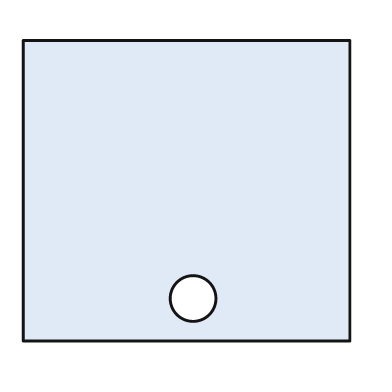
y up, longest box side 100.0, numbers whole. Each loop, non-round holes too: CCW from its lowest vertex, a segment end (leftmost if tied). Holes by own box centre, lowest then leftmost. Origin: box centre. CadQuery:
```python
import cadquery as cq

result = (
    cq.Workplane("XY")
    .moveTo(-50.0, -46.0)
    .lineTo(50.0, -46.0)
    .lineTo(50.0, 46.0)
    .lineTo(-50.0, 46.0)
    .close()
    .moveTo(2.0, -33.0)
    .circle(7.0)
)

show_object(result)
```